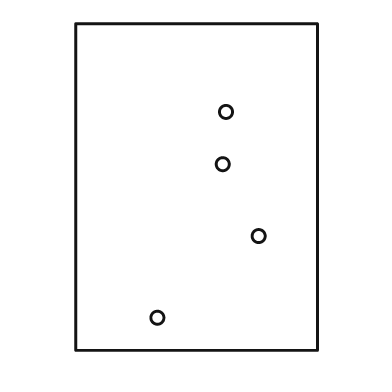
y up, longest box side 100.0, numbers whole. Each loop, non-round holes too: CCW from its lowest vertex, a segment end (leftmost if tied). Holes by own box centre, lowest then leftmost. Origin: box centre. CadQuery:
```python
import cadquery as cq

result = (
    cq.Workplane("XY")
    .moveTo(-37.0, -50.0)
    .lineTo(37.0, -50.0)
    .lineTo(37.0, 50.0)
    .lineTo(-37.0, 50.0)
    .close()
    .moveTo(-12.0, -40.0)
    .circle(2.0)
    .moveTo(19.0, -15.0)
    .circle(2.0)
    .moveTo(8.0, 7.0)
    .circle(2.0)
    .moveTo(9.0, 23.0)
    .circle(2.0)
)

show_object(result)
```